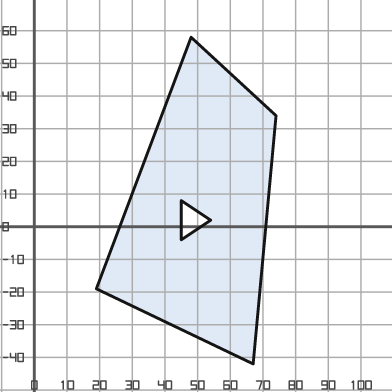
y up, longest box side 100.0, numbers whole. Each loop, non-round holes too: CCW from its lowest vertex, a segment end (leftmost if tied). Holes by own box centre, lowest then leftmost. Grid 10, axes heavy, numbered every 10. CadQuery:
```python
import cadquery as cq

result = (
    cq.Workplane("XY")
    .moveTo(67.0, -42.0)
    .lineTo(74.0, 34.0)
    .lineTo(48.0, 58.0)
    .lineTo(19.0, -19.0)
    .close()
    .moveTo(45.0, -4.0)
    .lineTo(54.0, 2.0)
    .lineTo(45.0, 8.0)
    .close()
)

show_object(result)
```